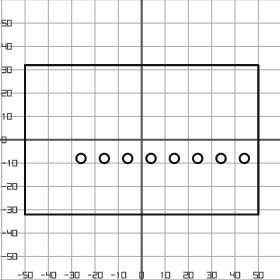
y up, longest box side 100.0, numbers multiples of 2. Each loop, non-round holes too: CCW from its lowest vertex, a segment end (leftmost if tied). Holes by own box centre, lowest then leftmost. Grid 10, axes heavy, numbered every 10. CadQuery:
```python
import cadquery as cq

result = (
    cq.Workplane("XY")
    .moveTo(-50.0, -32.0)
    .lineTo(50.0, -32.0)
    .lineTo(50.0, 32.0)
    .lineTo(-50.0, 32.0)
    .close()
    .moveTo(-26.0, -8.0)
    .circle(2.0)
    .moveTo(-16.0, -8.0)
    .circle(2.0)
    .moveTo(-6.0, -8.0)
    .circle(2.0)
    .moveTo(4.0, -8.0)
    .circle(2.0)
    .moveTo(14.0, -8.0)
    .circle(2.0)
    .moveTo(24.0, -8.0)
    .circle(2.0)
    .moveTo(34.0, -8.0)
    .circle(2.0)
    .moveTo(44.0, -8.0)
    .circle(2.0)
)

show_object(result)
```